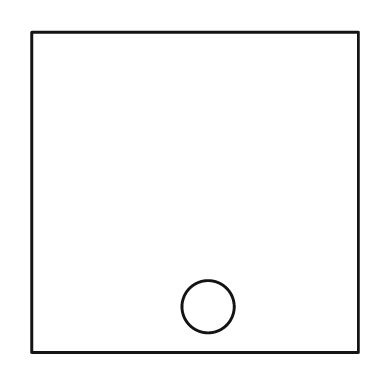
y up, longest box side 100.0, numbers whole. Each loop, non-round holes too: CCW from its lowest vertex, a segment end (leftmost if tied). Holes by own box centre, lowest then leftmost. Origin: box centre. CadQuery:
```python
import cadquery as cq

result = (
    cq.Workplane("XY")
    .moveTo(-50.0, -49.0)
    .lineTo(50.0, -49.0)
    .lineTo(50.0, 49.0)
    .lineTo(-50.0, 49.0)
    .close()
    .moveTo(4.0, -35.0)
    .circle(8.0)
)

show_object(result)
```